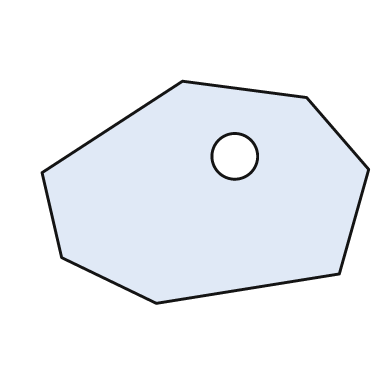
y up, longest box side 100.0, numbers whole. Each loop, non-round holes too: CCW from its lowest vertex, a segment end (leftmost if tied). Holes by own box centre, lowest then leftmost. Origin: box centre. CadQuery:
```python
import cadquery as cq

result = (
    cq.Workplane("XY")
    .moveTo(-15.0, -34.0)
    .lineTo(41.0, -25.0)
    .lineTo(50.0, 7.0)
    .lineTo(31.0, 29.0)
    .lineTo(-7.0, 34.0)
    .lineTo(-50.0, 6.0)
    .lineTo(-44.0, -20.0)
    .close()
    .moveTo(9.0, 11.0)
    .circle(7.0)
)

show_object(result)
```